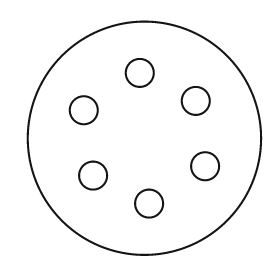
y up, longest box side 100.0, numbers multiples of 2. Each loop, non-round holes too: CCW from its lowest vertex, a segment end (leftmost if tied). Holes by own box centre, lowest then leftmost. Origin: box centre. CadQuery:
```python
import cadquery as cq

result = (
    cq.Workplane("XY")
    .moveTo(0.0, 0.0)
    .circle(50.0)
    .moveTo(2.0, -28.0)
    .circle(6.0)
    .moveTo(-22.0, -16.0)
    .circle(6.0)
    .moveTo(26.0, -12.0)
    .circle(6.0)
    .moveTo(-26.0, 12.0)
    .circle(6.0)
    .moveTo(22.0, 16.0)
    .circle(6.0)
    .moveTo(-2.0, 28.0)
    .circle(6.0)
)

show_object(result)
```